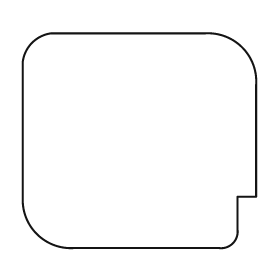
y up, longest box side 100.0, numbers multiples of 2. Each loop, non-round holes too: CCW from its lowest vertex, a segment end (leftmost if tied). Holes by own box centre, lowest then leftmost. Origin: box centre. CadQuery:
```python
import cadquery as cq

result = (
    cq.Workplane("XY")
    .moveTo(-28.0, -46.0)
    .lineTo(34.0, -46.0)
    .threePointArc((40.0, -44.0), (42.0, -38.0))
    .lineTo(42.0, -24.0)
    .lineTo(50.0, -24.0)
    .lineTo(50.0, 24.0)
    .threePointArc((44.0, 40.0), (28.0, 46.0))
    .lineTo(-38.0, 46.0)
    .threePointArc((-46.0, 42.0), (-50.0, 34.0))
    .lineTo(-50.0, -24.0)
    .threePointArc((-44.0, -40.0), (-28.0, -46.0))
    .close()
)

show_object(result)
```